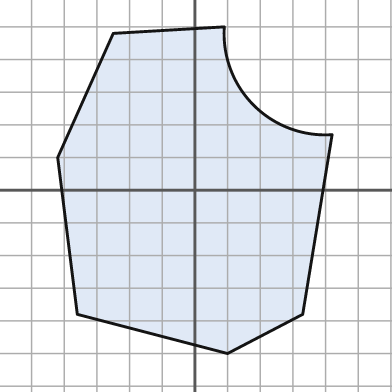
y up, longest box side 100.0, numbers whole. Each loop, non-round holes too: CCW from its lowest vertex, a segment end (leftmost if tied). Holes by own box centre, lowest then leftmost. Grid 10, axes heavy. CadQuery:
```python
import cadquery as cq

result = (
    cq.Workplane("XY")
    .moveTo(10.0, -50.0)
    .lineTo(33.0, -38.0)
    .lineTo(42.0, 17.0)
    .threePointArc((18.0, 26.0), (9.0, 50.0))
    .lineTo(-25.0, 48.0)
    .lineTo(-42.0, 10.0)
    .lineTo(-36.0, -38.0)
    .close()
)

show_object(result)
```